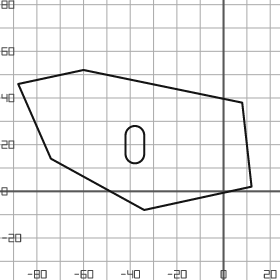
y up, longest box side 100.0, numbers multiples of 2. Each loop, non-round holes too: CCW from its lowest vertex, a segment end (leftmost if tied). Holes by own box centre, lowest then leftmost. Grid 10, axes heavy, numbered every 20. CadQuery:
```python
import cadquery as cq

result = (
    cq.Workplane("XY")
    .moveTo(-34.0, -8.0)
    .lineTo(12.0, 2.0)
    .lineTo(8.0, 38.0)
    .lineTo(-60.0, 52.0)
    .lineTo(-88.0, 46.0)
    .lineTo(-74.0, 14.0)
    .close()
    .moveTo(-42.0, 16.0)
    .threePointArc((-38.0, 12.0), (-34.0, 16.0))
    .lineTo(-34.0, 24.0)
    .threePointArc((-38.0, 28.0), (-42.0, 24.0))
    .close()
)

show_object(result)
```